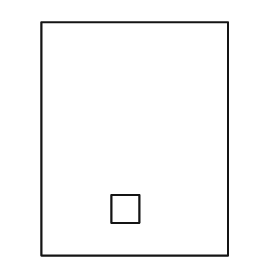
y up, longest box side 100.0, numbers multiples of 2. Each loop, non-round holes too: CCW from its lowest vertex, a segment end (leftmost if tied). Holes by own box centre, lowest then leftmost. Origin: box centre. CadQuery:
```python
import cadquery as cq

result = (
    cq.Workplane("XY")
    .moveTo(-40.0, -50.0)
    .lineTo(40.0, -50.0)
    .lineTo(40.0, 50.0)
    .lineTo(-40.0, 50.0)
    .close()
    .moveTo(-10.0, -36.0)
    .lineTo(2.0, -36.0)
    .lineTo(2.0, -24.0)
    .lineTo(-10.0, -24.0)
    .close()
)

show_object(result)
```